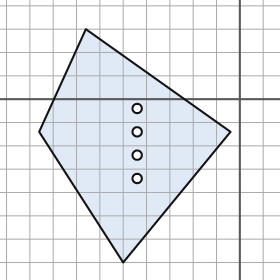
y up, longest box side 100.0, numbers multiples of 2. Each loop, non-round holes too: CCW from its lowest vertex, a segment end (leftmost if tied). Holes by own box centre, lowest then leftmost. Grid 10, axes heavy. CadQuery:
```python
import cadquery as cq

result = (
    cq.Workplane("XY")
    .moveTo(-50.0, -70.0)
    .lineTo(-4.0, -14.0)
    .lineTo(-66.0, 30.0)
    .lineTo(-86.0, -14.0)
    .close()
    .moveTo(-44.0, -34.0)
    .circle(2.0)
    .moveTo(-44.0, -24.0)
    .circle(2.0)
    .moveTo(-44.0, -14.0)
    .circle(2.0)
    .moveTo(-44.0, -4.0)
    .circle(2.0)
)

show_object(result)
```